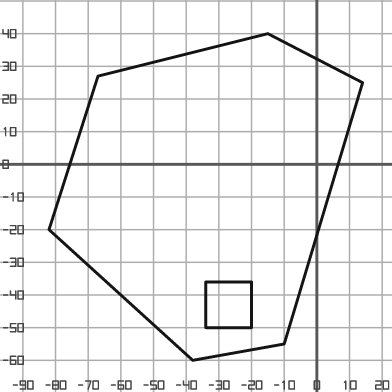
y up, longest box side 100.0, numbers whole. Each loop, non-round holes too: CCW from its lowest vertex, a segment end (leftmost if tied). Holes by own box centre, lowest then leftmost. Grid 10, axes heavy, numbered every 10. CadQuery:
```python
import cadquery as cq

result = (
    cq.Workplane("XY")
    .moveTo(-38.0, -60.0)
    .lineTo(-10.0, -55.0)
    .lineTo(14.0, 25.0)
    .lineTo(-15.0, 40.0)
    .lineTo(-67.0, 27.0)
    .lineTo(-82.0, -20.0)
    .close()
    .moveTo(-34.0, -50.0)
    .lineTo(-20.0, -50.0)
    .lineTo(-20.0, -36.0)
    .lineTo(-34.0, -36.0)
    .close()
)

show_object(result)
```